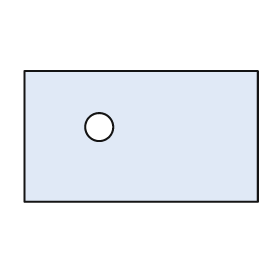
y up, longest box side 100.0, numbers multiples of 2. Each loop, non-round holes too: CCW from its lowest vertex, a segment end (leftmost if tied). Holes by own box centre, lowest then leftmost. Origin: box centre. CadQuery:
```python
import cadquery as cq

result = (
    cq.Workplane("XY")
    .moveTo(-50.0, -28.0)
    .lineTo(50.0, -28.0)
    .lineTo(50.0, 28.0)
    .lineTo(-50.0, 28.0)
    .close()
    .moveTo(-18.0, 4.0)
    .circle(6.0)
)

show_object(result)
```